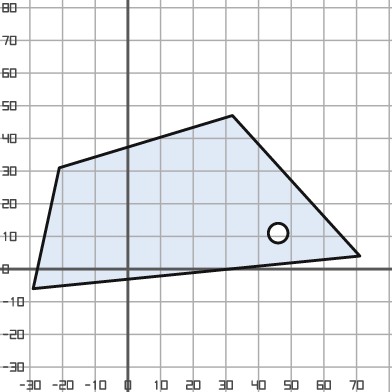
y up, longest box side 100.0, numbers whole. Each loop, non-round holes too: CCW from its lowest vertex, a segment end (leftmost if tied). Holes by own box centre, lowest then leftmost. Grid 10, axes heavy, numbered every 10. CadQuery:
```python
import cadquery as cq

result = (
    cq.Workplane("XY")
    .moveTo(-29.0, -6.0)
    .lineTo(71.0, 4.0)
    .lineTo(32.0, 47.0)
    .lineTo(-21.0, 31.0)
    .close()
    .moveTo(46.0, 11.0)
    .circle(3.0)
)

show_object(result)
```